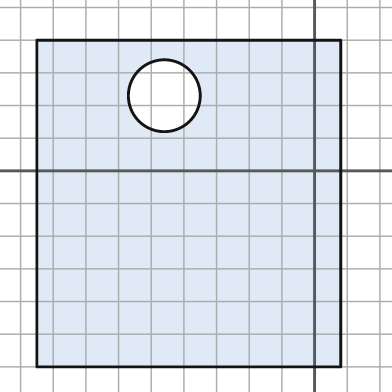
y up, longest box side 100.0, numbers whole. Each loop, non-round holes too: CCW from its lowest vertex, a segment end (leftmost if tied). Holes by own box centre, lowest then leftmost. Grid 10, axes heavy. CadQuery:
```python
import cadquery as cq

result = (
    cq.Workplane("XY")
    .moveTo(-85.0, -60.0)
    .lineTo(8.0, -60.0)
    .lineTo(8.0, 40.0)
    .lineTo(-85.0, 40.0)
    .close()
    .moveTo(-46.0, 23.0)
    .circle(11.0)
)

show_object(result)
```